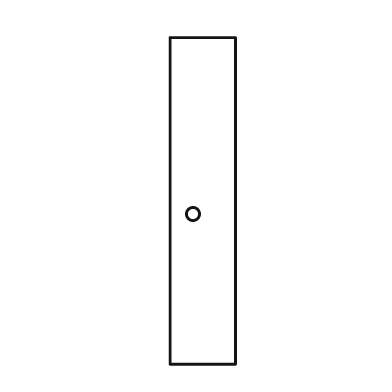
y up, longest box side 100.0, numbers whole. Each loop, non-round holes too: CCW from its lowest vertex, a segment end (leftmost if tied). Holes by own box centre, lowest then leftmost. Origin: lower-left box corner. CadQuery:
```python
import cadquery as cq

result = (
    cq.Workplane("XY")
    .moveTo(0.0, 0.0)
    .lineTo(20.0, 0.0)
    .lineTo(20.0, 100.0)
    .lineTo(0.0, 100.0)
    .close()
    .moveTo(7.0, 46.0)
    .circle(2.0)
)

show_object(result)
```